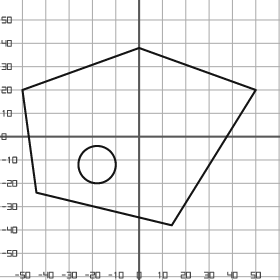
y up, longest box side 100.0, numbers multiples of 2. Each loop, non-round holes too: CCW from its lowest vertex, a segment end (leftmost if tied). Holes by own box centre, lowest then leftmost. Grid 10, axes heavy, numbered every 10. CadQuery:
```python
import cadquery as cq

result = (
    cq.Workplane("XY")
    .moveTo(14.0, -38.0)
    .lineTo(50.0, 20.0)
    .lineTo(0.0, 38.0)
    .lineTo(-50.0, 20.0)
    .lineTo(-44.0, -24.0)
    .close()
    .moveTo(-18.0, -12.0)
    .circle(8.0)
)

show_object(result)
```